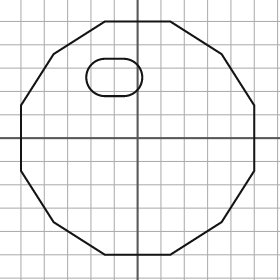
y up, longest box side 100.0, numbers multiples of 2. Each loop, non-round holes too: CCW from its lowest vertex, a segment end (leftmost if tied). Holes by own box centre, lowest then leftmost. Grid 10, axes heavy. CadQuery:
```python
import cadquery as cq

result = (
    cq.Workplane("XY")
    .moveTo(-14.0, -50.0)
    .lineTo(14.0, -50.0)
    .lineTo(36.0, -36.0)
    .lineTo(50.0, -14.0)
    .lineTo(50.0, 14.0)
    .lineTo(36.0, 36.0)
    .lineTo(14.0, 50.0)
    .lineTo(-14.0, 50.0)
    .lineTo(-36.0, 36.0)
    .lineTo(-50.0, 14.0)
    .lineTo(-50.0, -14.0)
    .lineTo(-36.0, -36.0)
    .close()
    .moveTo(-14.0, 18.0)
    .lineTo(-6.0, 18.0)
    .threePointArc((2.0, 26.0), (-6.0, 34.0))
    .lineTo(-14.0, 34.0)
    .threePointArc((-22.0, 26.0), (-14.0, 18.0))
    .close()
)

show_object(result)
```